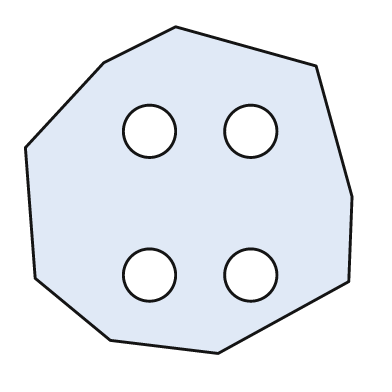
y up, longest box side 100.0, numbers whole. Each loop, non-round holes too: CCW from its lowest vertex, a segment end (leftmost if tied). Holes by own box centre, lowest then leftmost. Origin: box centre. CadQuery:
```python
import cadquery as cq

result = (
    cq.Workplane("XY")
    .moveTo(9.0, -50.0)
    .lineTo(49.0, -28.0)
    .lineTo(50.0, -2.0)
    .lineTo(39.0, 38.0)
    .lineTo(-4.0, 50.0)
    .lineTo(-26.0, 39.0)
    .lineTo(-50.0, 13.0)
    .lineTo(-47.0, -27.0)
    .lineTo(-24.0, -46.0)
    .close()
    .moveTo(-12.0, -26.0)
    .circle(8.0)
    .moveTo(19.0, -26.0)
    .circle(8.0)
    .moveTo(-12.0, 18.0)
    .circle(8.0)
    .moveTo(19.0, 18.0)
    .circle(8.0)
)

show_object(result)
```